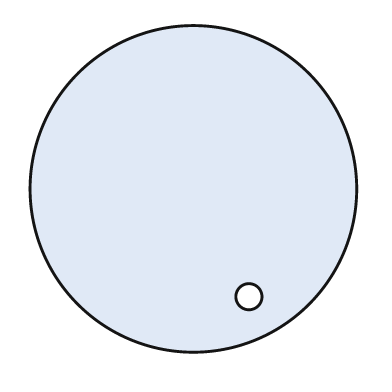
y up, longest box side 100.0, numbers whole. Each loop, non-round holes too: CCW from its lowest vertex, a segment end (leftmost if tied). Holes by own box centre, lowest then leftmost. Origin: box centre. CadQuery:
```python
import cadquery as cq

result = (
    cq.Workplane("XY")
    .moveTo(0.0, 0.0)
    .circle(50.0)
    .moveTo(17.0, -33.0)
    .circle(4.0)
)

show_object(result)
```